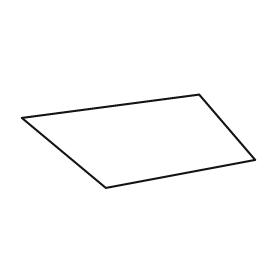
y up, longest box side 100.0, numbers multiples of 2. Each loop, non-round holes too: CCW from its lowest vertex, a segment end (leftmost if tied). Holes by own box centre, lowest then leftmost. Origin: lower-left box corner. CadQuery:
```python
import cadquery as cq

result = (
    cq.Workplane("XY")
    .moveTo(36.0, 0.0)
    .lineTo(100.0, 12.0)
    .lineTo(76.0, 40.0)
    .lineTo(0.0, 30.0)
    .close()
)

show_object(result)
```